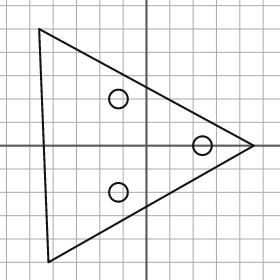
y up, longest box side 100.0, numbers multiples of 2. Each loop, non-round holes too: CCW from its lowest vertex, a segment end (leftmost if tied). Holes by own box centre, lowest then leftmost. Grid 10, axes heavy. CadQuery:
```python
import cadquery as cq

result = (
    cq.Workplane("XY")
    .moveTo(-42.0, -50.0)
    .lineTo(46.0, 0.0)
    .lineTo(-46.0, 50.0)
    .close()
    .moveTo(-12.0, -20.0)
    .circle(4.0)
    .moveTo(24.0, 0.0)
    .circle(4.0)
    .moveTo(-12.0, 20.0)
    .circle(4.0)
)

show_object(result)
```